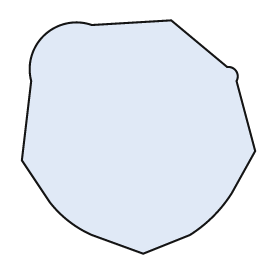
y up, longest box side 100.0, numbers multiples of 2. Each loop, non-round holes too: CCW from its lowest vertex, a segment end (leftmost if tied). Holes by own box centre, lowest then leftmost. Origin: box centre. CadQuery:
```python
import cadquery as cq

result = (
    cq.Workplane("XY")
    .moveTo(2.0, -50.0)
    .lineTo(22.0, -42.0)
    .threePointArc((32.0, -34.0), (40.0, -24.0))
    .lineTo(50.0, -6.0)
    .lineTo(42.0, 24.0)
    .threePointArc((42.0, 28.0), (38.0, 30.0))
    .lineTo(14.0, 50.0)
    .lineTo(-20.0, 48.0)
    .threePointArc((-40.0, 44.0), (-46.0, 24.0))
    .lineTo(-50.0, -10.0)
    .lineTo(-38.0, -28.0)
    .threePointArc((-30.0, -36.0), (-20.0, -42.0))
    .close()
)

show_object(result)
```